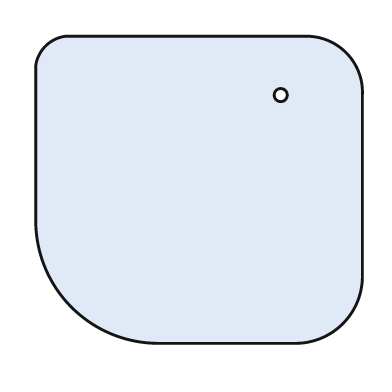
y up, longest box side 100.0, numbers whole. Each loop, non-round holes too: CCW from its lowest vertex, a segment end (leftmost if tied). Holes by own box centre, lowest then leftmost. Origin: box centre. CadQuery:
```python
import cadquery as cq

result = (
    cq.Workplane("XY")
    .moveTo(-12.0, -47.0)
    .lineTo(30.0, -47.0)
    .threePointArc((44.0, -41.0), (50.0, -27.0))
    .lineTo(50.0, 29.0)
    .threePointArc((45.0, 42.0), (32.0, 47.0))
    .lineTo(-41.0, 47.0)
    .threePointArc((-47.0, 44.0), (-50.0, 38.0))
    .lineTo(-50.0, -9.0)
    .threePointArc((-39.0, -36.0), (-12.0, -47.0))
    .close()
    .moveTo(25.0, 29.0)
    .circle(2.0)
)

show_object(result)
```